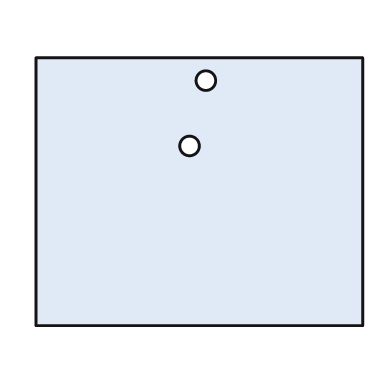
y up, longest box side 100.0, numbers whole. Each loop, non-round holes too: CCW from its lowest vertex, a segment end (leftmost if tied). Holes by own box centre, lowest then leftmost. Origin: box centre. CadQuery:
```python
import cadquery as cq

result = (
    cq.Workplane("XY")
    .moveTo(-50.0, -41.0)
    .lineTo(50.0, -41.0)
    .lineTo(50.0, 41.0)
    .lineTo(-50.0, 41.0)
    .close()
    .moveTo(-3.0, 14.0)
    .circle(3.0)
    .moveTo(2.0, 34.0)
    .circle(3.0)
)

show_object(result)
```